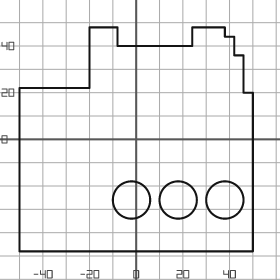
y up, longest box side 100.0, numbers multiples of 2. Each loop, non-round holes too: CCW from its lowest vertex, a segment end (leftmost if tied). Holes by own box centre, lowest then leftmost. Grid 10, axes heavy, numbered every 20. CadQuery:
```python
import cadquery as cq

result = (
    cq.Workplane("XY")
    .moveTo(-50.0, -48.0)
    .lineTo(50.0, -48.0)
    .lineTo(50.0, 20.0)
    .lineTo(46.0, 20.0)
    .lineTo(46.0, 36.0)
    .lineTo(42.0, 36.0)
    .lineTo(42.0, 44.0)
    .lineTo(38.0, 44.0)
    .lineTo(38.0, 48.0)
    .lineTo(24.0, 48.0)
    .lineTo(24.0, 40.0)
    .lineTo(-8.0, 40.0)
    .lineTo(-8.0, 48.0)
    .lineTo(-20.0, 48.0)
    .lineTo(-20.0, 22.0)
    .lineTo(-50.0, 22.0)
    .close()
    .moveTo(-2.0, -26.0)
    .circle(8.0)
    .moveTo(18.0, -26.0)
    .circle(8.0)
    .moveTo(38.0, -26.0)
    .circle(8.0)
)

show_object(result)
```